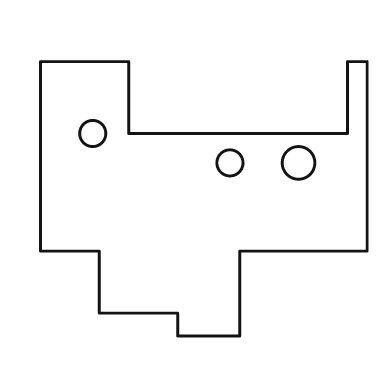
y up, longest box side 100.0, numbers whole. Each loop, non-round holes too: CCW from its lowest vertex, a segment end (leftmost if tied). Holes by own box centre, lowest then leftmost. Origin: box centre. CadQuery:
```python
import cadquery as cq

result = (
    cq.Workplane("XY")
    .moveTo(-8.0, -42.0)
    .lineTo(11.0, -42.0)
    .lineTo(11.0, -16.0)
    .lineTo(50.0, -16.0)
    .lineTo(50.0, 42.0)
    .lineTo(44.0, 42.0)
    .lineTo(44.0, 20.0)
    .lineTo(-23.0, 20.0)
    .lineTo(-23.0, 42.0)
    .lineTo(-50.0, 42.0)
    .lineTo(-50.0, -16.0)
    .lineTo(-32.0, -16.0)
    .lineTo(-32.0, -35.0)
    .lineTo(-8.0, -35.0)
    .close()
    .moveTo(8.0, 11.0)
    .circle(4.0)
    .moveTo(29.0, 11.0)
    .circle(5.0)
    .moveTo(-34.0, 20.0)
    .circle(4.0)
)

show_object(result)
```